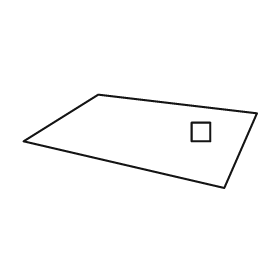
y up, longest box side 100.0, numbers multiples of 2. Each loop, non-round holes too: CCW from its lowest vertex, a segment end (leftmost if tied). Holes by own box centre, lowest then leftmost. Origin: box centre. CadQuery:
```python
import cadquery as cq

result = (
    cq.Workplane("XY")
    .moveTo(36.0, -20.0)
    .lineTo(50.0, 12.0)
    .lineTo(-18.0, 20.0)
    .lineTo(-50.0, 0.0)
    .close()
    .moveTo(22.0, 0.0)
    .lineTo(30.0, 0.0)
    .lineTo(30.0, 8.0)
    .lineTo(22.0, 8.0)
    .close()
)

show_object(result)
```